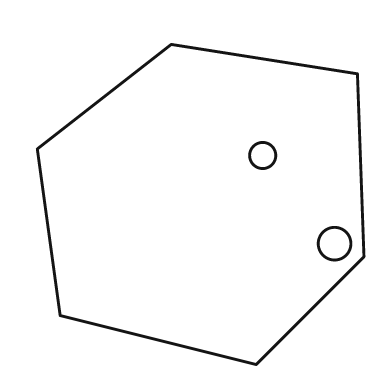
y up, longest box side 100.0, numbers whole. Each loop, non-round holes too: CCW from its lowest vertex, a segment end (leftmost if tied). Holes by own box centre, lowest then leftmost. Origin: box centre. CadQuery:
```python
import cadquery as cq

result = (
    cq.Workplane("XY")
    .moveTo(17.0, -49.0)
    .lineTo(50.0, -16.0)
    .lineTo(48.0, 40.0)
    .lineTo(-9.0, 49.0)
    .lineTo(-50.0, 17.0)
    .lineTo(-43.0, -34.0)
    .close()
    .moveTo(41.0, -12.0)
    .circle(5.0)
    .moveTo(19.0, 15.0)
    .circle(4.0)
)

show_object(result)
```